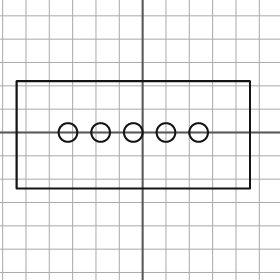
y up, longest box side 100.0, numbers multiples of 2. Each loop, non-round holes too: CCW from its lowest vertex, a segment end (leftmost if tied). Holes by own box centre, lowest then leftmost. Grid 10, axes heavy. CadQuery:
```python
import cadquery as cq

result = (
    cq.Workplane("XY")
    .moveTo(-54.0, -24.0)
    .lineTo(46.0, -24.0)
    .lineTo(46.0, 22.0)
    .lineTo(-54.0, 22.0)
    .close()
    .moveTo(-32.0, 0.0)
    .circle(4.0)
    .moveTo(-18.0, 0.0)
    .circle(4.0)
    .moveTo(-4.0, 0.0)
    .circle(4.0)
    .moveTo(10.0, 0.0)
    .circle(4.0)
    .moveTo(24.0, 0.0)
    .circle(4.0)
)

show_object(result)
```